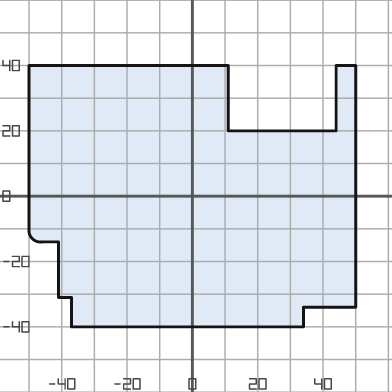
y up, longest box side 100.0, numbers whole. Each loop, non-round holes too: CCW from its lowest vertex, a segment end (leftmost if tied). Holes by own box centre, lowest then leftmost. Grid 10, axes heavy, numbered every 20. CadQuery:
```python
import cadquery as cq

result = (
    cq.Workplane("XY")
    .moveTo(-37.0, -40.0)
    .lineTo(34.0, -40.0)
    .lineTo(34.0, -34.0)
    .lineTo(50.0, -34.0)
    .lineTo(50.0, 40.0)
    .lineTo(44.0, 40.0)
    .lineTo(44.0, 20.0)
    .lineTo(11.0, 20.0)
    .lineTo(11.0, 40.0)
    .lineTo(-50.0, 40.0)
    .lineTo(-50.0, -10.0)
    .threePointArc((-49.0, -13.0), (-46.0, -14.0))
    .lineTo(-41.0, -14.0)
    .lineTo(-41.0, -31.0)
    .lineTo(-37.0, -31.0)
    .close()
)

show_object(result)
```